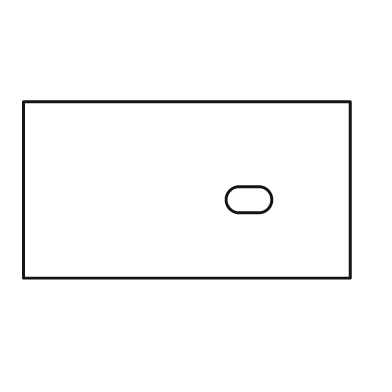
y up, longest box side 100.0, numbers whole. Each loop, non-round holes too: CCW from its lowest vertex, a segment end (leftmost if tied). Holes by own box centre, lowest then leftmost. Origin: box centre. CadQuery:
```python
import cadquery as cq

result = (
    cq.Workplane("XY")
    .moveTo(-50.0, -27.0)
    .lineTo(50.0, -27.0)
    .lineTo(50.0, 27.0)
    .lineTo(-50.0, 27.0)
    .close()
    .moveTo(16.0, -7.0)
    .lineTo(22.0, -7.0)
    .threePointArc((26.0, -3.0), (22.0, 1.0))
    .lineTo(16.0, 1.0)
    .threePointArc((12.0, -3.0), (16.0, -7.0))
    .close()
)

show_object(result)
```